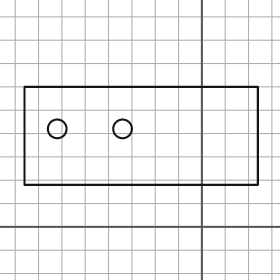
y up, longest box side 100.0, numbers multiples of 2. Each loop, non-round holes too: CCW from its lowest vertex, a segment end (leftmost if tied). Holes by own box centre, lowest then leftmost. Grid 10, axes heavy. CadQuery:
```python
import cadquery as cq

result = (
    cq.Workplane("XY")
    .moveTo(-76.0, 18.0)
    .lineTo(24.0, 18.0)
    .lineTo(24.0, 60.0)
    .lineTo(-76.0, 60.0)
    .close()
    .moveTo(-62.0, 42.0)
    .circle(4.0)
    .moveTo(-34.0, 42.0)
    .circle(4.0)
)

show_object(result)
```